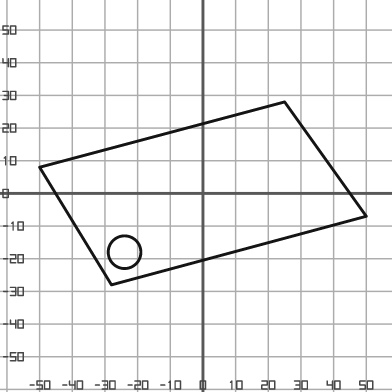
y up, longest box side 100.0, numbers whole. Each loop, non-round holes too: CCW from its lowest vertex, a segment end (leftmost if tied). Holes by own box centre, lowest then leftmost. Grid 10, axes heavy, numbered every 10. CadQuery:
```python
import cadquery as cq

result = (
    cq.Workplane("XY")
    .moveTo(-28.0, -28.0)
    .lineTo(50.0, -7.0)
    .lineTo(25.0, 28.0)
    .lineTo(-50.0, 8.0)
    .close()
    .moveTo(-24.0, -18.0)
    .circle(5.0)
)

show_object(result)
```